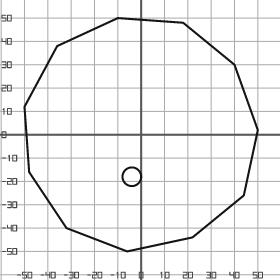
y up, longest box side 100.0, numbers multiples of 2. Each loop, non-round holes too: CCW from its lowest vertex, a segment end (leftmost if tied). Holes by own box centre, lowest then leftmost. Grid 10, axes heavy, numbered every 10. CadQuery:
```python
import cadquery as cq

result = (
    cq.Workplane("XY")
    .moveTo(-6.0, -50.0)
    .lineTo(22.0, -44.0)
    .lineTo(44.0, -26.0)
    .lineTo(50.0, 2.0)
    .lineTo(40.0, 30.0)
    .lineTo(18.0, 48.0)
    .lineTo(-10.0, 50.0)
    .lineTo(-36.0, 38.0)
    .lineTo(-50.0, 12.0)
    .lineTo(-48.0, -16.0)
    .lineTo(-32.0, -40.0)
    .close()
    .moveTo(-4.0, -18.0)
    .circle(4.0)
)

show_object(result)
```